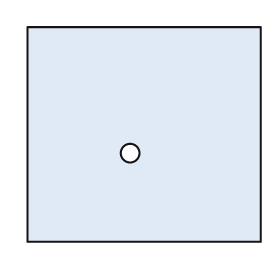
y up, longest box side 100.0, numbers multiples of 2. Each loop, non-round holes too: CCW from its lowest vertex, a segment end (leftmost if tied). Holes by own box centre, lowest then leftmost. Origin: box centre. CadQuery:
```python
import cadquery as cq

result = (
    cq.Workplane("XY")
    .moveTo(-50.0, -46.0)
    .lineTo(50.0, -46.0)
    .lineTo(50.0, 46.0)
    .lineTo(-50.0, 46.0)
    .close()
    .moveTo(-6.0, -8.0)
    .circle(4.0)
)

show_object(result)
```